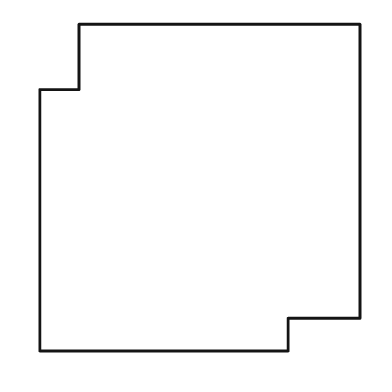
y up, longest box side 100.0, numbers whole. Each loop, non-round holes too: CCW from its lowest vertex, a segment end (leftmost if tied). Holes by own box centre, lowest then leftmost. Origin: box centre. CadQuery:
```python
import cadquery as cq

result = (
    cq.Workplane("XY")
    .moveTo(-49.0, -50.0)
    .lineTo(27.0, -50.0)
    .lineTo(27.0, -40.0)
    .lineTo(49.0, -40.0)
    .lineTo(49.0, 50.0)
    .lineTo(-37.0, 50.0)
    .lineTo(-37.0, 30.0)
    .lineTo(-49.0, 30.0)
    .close()
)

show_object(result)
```